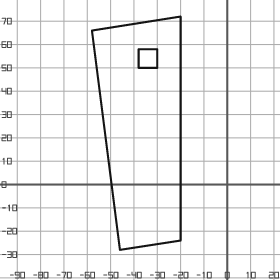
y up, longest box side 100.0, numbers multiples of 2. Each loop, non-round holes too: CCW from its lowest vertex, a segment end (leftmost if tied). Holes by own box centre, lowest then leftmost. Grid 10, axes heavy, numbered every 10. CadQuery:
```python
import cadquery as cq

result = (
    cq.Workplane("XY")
    .moveTo(-46.0, -28.0)
    .lineTo(-20.0, -24.0)
    .lineTo(-20.0, 72.0)
    .lineTo(-58.0, 66.0)
    .close()
    .moveTo(-38.0, 50.0)
    .lineTo(-30.0, 50.0)
    .lineTo(-30.0, 58.0)
    .lineTo(-38.0, 58.0)
    .close()
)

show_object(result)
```